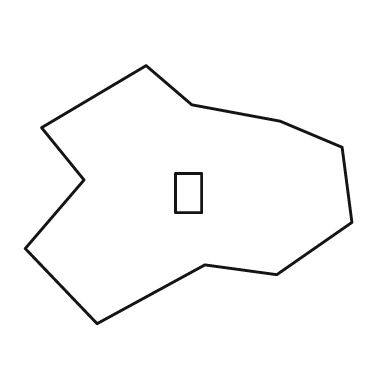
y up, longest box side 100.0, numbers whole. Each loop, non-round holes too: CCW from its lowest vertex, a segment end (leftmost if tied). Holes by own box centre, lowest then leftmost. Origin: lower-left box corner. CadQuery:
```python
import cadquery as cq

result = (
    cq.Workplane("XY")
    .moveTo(22.0, 0.0)
    .lineTo(55.0, 18.0)
    .lineTo(77.0, 15.0)
    .lineTo(100.0, 31.0)
    .lineTo(97.0, 54.0)
    .lineTo(78.0, 62.0)
    .lineTo(51.0, 67.0)
    .lineTo(37.0, 79.0)
    .lineTo(5.0, 60.0)
    .lineTo(18.0, 44.0)
    .lineTo(0.0, 23.0)
    .close()
    .moveTo(46.0, 34.0)
    .lineTo(54.0, 34.0)
    .lineTo(54.0, 46.0)
    .lineTo(46.0, 46.0)
    .close()
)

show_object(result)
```